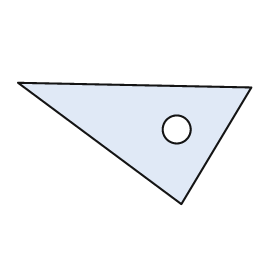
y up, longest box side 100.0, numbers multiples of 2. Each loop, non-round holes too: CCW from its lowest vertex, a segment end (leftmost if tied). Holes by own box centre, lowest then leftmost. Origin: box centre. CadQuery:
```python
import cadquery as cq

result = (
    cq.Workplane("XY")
    .moveTo(20.0, -26.0)
    .lineTo(50.0, 24.0)
    .lineTo(-50.0, 26.0)
    .close()
    .moveTo(18.0, 6.0)
    .circle(6.0)
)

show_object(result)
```